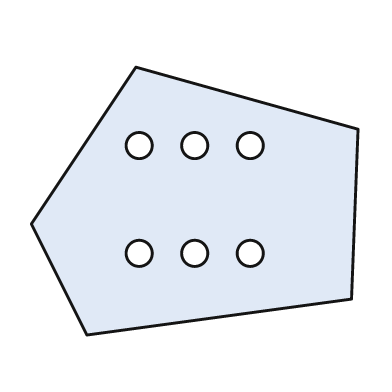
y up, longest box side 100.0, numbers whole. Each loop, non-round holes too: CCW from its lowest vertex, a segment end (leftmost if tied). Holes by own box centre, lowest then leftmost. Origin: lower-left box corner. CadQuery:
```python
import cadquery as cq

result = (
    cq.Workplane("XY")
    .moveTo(17.0, 0.0)
    .lineTo(98.0, 11.0)
    .lineTo(100.0, 63.0)
    .lineTo(32.0, 82.0)
    .lineTo(0.0, 34.0)
    .close()
    .moveTo(33.0, 25.0)
    .circle(4.0)
    .moveTo(50.0, 25.0)
    .circle(4.0)
    .moveTo(67.0, 25.0)
    .circle(4.0)
    .moveTo(33.0, 58.0)
    .circle(4.0)
    .moveTo(50.0, 58.0)
    .circle(4.0)
    .moveTo(67.0, 58.0)
    .circle(4.0)
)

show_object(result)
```